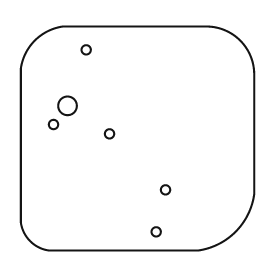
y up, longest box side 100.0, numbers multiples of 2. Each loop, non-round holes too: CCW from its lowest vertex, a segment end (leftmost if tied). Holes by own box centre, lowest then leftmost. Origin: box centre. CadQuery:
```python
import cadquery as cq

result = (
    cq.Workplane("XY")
    .moveTo(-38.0, -48.0)
    .lineTo(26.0, -48.0)
    .threePointArc((42.0, -40.0), (50.0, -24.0))
    .lineTo(50.0, 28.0)
    .threePointArc((44.0, 42.0), (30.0, 48.0))
    .lineTo(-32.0, 48.0)
    .threePointArc((-44.0, 42.0), (-50.0, 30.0))
    .lineTo(-50.0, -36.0)
    .threePointArc((-46.0, -44.0), (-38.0, -48.0))
    .close()
    .moveTo(8.0, -40.0)
    .circle(2.0)
    .moveTo(12.0, -22.0)
    .circle(2.0)
    .moveTo(-12.0, 2.0)
    .circle(2.0)
    .moveTo(-36.0, 6.0)
    .circle(2.0)
    .moveTo(-30.0, 14.0)
    .circle(4.0)
    .moveTo(-22.0, 38.0)
    .circle(2.0)
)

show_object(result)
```